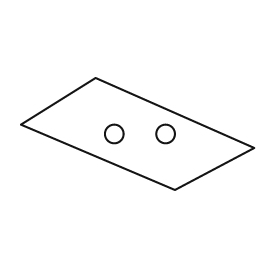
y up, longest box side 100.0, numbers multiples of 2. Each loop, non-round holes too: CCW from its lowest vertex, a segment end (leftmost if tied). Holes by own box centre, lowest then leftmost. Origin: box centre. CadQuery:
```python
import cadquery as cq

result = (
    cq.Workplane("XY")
    .moveTo(16.0, -24.0)
    .lineTo(50.0, -6.0)
    .lineTo(-18.0, 24.0)
    .lineTo(-50.0, 4.0)
    .close()
    .moveTo(-10.0, 0.0)
    .circle(4.0)
    .moveTo(12.0, 0.0)
    .circle(4.0)
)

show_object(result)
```